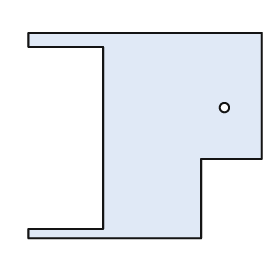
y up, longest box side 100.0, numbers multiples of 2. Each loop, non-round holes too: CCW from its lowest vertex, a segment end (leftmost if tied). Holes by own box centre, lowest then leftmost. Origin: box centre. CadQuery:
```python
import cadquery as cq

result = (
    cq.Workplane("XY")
    .moveTo(-50.0, -44.0)
    .lineTo(24.0, -44.0)
    .lineTo(24.0, -10.0)
    .lineTo(50.0, -10.0)
    .lineTo(50.0, 44.0)
    .lineTo(-50.0, 44.0)
    .lineTo(-50.0, 38.0)
    .lineTo(-18.0, 38.0)
    .lineTo(-18.0, -40.0)
    .lineTo(-50.0, -40.0)
    .close()
    .moveTo(34.0, 12.0)
    .circle(2.0)
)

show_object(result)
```